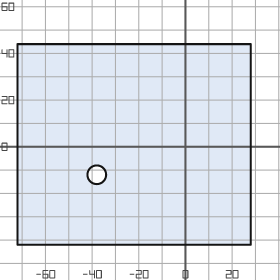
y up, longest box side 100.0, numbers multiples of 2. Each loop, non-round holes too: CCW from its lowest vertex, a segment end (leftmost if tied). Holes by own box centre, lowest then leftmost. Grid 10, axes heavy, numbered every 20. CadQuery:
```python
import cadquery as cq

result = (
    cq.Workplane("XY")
    .moveTo(-72.0, -42.0)
    .lineTo(28.0, -42.0)
    .lineTo(28.0, 44.0)
    .lineTo(-72.0, 44.0)
    .close()
    .moveTo(-38.0, -12.0)
    .circle(4.0)
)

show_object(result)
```